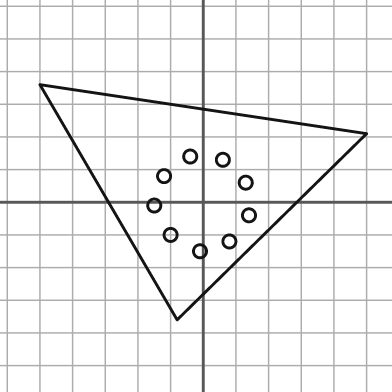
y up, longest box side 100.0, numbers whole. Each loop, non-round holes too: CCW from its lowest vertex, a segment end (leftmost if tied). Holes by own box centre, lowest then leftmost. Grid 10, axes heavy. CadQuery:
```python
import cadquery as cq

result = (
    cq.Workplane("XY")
    .moveTo(-8.0, -36.0)
    .lineTo(50.0, 21.0)
    .lineTo(-50.0, 36.0)
    .close()
    .moveTo(-1.0, -15.0)
    .circle(2.0)
    .moveTo(8.0, -12.0)
    .circle(2.0)
    .moveTo(-10.0, -10.0)
    .circle(2.0)
    .moveTo(14.0, -4.0)
    .circle(2.0)
    .moveTo(-15.0, -1.0)
    .circle(2.0)
    .moveTo(13.0, 6.0)
    .circle(2.0)
    .moveTo(-12.0, 8.0)
    .circle(2.0)
    .moveTo(6.0, 13.0)
    .circle(2.0)
    .moveTo(-4.0, 14.0)
    .circle(2.0)
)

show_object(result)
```